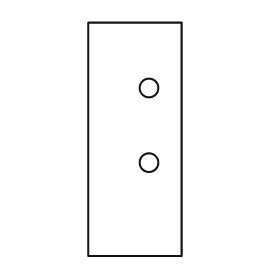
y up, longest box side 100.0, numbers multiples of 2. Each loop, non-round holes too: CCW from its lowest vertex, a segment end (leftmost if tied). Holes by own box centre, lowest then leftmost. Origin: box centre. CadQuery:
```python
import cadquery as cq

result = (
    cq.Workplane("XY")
    .moveTo(-20.0, -50.0)
    .lineTo(20.0, -50.0)
    .lineTo(20.0, 50.0)
    .lineTo(-20.0, 50.0)
    .close()
    .moveTo(6.0, -10.0)
    .circle(4.0)
    .moveTo(6.0, 22.0)
    .circle(4.0)
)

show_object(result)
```